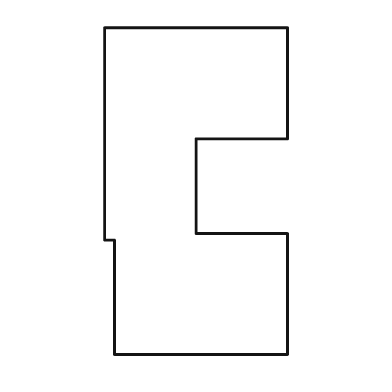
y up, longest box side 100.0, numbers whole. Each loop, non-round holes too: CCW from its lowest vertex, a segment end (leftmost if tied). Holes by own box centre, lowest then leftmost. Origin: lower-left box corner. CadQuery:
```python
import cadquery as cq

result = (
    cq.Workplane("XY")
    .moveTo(3.0, 0.0)
    .lineTo(56.0, 0.0)
    .lineTo(56.0, 37.0)
    .lineTo(28.0, 37.0)
    .lineTo(28.0, 66.0)
    .lineTo(56.0, 66.0)
    .lineTo(56.0, 100.0)
    .lineTo(0.0, 100.0)
    .lineTo(0.0, 35.0)
    .lineTo(3.0, 35.0)
    .close()
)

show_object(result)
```